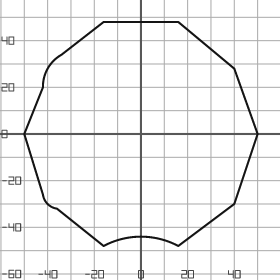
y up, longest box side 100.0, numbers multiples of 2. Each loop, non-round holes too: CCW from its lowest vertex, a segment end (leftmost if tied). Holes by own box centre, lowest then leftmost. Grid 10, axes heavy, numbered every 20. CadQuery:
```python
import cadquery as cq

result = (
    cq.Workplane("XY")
    .moveTo(-16.0, -48.0)
    .threePointArc((0.0, -44.0), (16.0, -48.0))
    .lineTo(40.0, -30.0)
    .lineTo(50.0, 0.0)
    .lineTo(40.0, 28.0)
    .lineTo(16.0, 48.0)
    .lineTo(-16.0, 48.0)
    .lineTo(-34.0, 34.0)
    .threePointArc((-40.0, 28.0), (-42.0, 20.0))
    .lineTo(-50.0, 0.0)
    .lineTo(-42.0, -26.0)
    .threePointArc((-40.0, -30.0), (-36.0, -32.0))
    .close()
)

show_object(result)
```